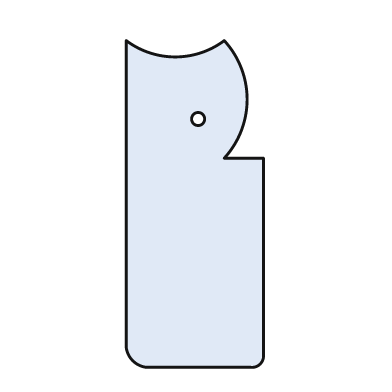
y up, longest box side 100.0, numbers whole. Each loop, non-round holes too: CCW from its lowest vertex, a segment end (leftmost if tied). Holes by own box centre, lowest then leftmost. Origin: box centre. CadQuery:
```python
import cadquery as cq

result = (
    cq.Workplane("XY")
    .moveTo(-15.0, -50.0)
    .lineTo(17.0, -50.0)
    .threePointArc((20.0, -49.0), (21.0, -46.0))
    .lineTo(21.0, 14.0)
    .lineTo(9.0, 14.0)
    .threePointArc((16.0, 32.0), (9.0, 50.0))
    .threePointArc((-6.0, 45.0), (-21.0, 50.0))
    .lineTo(-21.0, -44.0)
    .threePointArc((-19.0, -48.0), (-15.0, -50.0))
    .close()
    .moveTo(1.0, 26.0)
    .circle(2.0)
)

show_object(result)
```